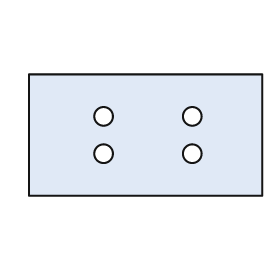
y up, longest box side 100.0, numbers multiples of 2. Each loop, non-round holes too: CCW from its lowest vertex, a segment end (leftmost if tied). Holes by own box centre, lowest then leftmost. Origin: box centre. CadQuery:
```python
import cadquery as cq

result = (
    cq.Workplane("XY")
    .moveTo(-50.0, -26.0)
    .lineTo(50.0, -26.0)
    .lineTo(50.0, 26.0)
    .lineTo(-50.0, 26.0)
    .close()
    .moveTo(-18.0, -8.0)
    .circle(4.0)
    .moveTo(20.0, -8.0)
    .circle(4.0)
    .moveTo(-18.0, 8.0)
    .circle(4.0)
    .moveTo(20.0, 8.0)
    .circle(4.0)
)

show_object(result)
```